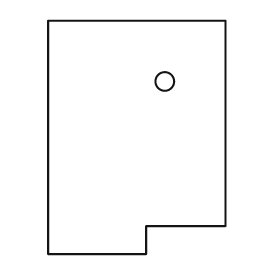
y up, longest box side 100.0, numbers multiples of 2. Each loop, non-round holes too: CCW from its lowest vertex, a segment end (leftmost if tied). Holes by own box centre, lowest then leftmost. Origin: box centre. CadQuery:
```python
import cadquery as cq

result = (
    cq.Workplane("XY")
    .moveTo(-38.0, -50.0)
    .lineTo(4.0, -50.0)
    .lineTo(4.0, -38.0)
    .lineTo(38.0, -38.0)
    .lineTo(38.0, 50.0)
    .lineTo(-38.0, 50.0)
    .close()
    .moveTo(12.0, 24.0)
    .circle(4.0)
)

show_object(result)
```